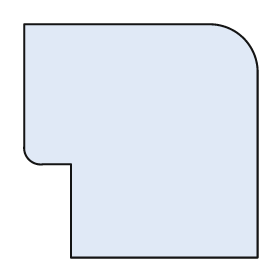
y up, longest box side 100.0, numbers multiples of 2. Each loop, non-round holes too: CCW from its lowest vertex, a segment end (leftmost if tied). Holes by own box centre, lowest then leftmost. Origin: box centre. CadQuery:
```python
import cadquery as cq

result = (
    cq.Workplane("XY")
    .moveTo(-30.0, -50.0)
    .lineTo(50.0, -50.0)
    .lineTo(50.0, 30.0)
    .threePointArc((44.0, 44.0), (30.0, 50.0))
    .lineTo(-50.0, 50.0)
    .lineTo(-50.0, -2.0)
    .threePointArc((-48.0, -8.0), (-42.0, -10.0))
    .lineTo(-30.0, -10.0)
    .close()
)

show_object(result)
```